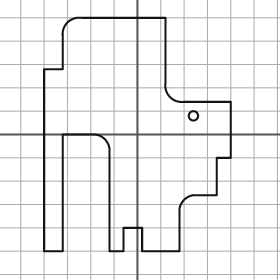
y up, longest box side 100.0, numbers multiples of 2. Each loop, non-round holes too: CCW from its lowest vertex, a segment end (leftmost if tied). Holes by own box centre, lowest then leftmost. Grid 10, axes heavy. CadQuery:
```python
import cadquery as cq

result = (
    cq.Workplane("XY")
    .moveTo(-40.0, -50.0)
    .lineTo(-32.0, -50.0)
    .lineTo(-32.0, 0.0)
    .lineTo(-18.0, 0.0)
    .threePointArc((-14.0, -2.0), (-12.0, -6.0))
    .lineTo(-12.0, -50.0)
    .lineTo(-6.0, -50.0)
    .lineTo(-6.0, -40.0)
    .lineTo(2.0, -40.0)
    .lineTo(2.0, -50.0)
    .lineTo(18.0, -50.0)
    .lineTo(18.0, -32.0)
    .threePointArc((20.0, -28.0), (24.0, -26.0))
    .lineTo(34.0, -26.0)
    .lineTo(34.0, -10.0)
    .lineTo(40.0, -10.0)
    .lineTo(40.0, 14.0)
    .lineTo(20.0, 14.0)
    .threePointArc((14.0, 16.0), (12.0, 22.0))
    .lineTo(12.0, 50.0)
    .lineTo(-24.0, 50.0)
    .threePointArc((-30.0, 48.0), (-32.0, 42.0))
    .lineTo(-32.0, 28.0)
    .lineTo(-40.0, 28.0)
    .close()
    .moveTo(24.0, 8.0)
    .circle(2.0)
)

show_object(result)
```